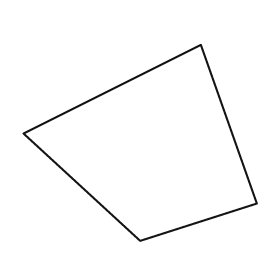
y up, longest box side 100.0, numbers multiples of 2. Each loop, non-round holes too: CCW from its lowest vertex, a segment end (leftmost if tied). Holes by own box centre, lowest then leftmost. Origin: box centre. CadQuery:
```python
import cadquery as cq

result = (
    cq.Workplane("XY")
    .moveTo(0.0, -42.0)
    .lineTo(50.0, -26.0)
    .lineTo(26.0, 42.0)
    .lineTo(-50.0, 4.0)
    .close()
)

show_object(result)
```